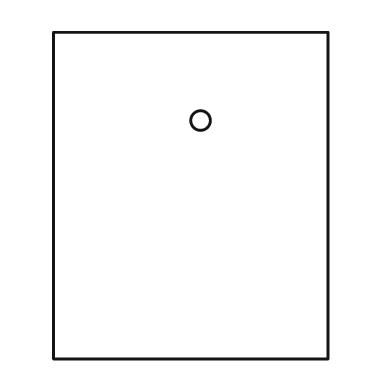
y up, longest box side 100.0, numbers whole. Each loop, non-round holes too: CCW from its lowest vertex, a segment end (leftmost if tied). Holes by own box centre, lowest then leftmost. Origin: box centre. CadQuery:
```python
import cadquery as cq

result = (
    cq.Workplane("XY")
    .moveTo(-42.0, -50.0)
    .lineTo(42.0, -50.0)
    .lineTo(42.0, 50.0)
    .lineTo(-42.0, 50.0)
    .close()
    .moveTo(3.0, 23.0)
    .circle(3.0)
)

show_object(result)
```